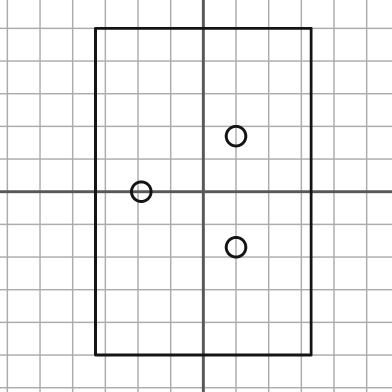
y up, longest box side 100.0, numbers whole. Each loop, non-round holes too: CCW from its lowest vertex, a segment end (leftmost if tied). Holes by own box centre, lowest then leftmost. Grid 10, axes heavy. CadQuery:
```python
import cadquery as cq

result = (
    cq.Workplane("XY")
    .moveTo(-33.0, -50.0)
    .lineTo(33.0, -50.0)
    .lineTo(33.0, 50.0)
    .lineTo(-33.0, 50.0)
    .close()
    .moveTo(10.0, -17.0)
    .circle(3.0)
    .moveTo(-19.0, 0.0)
    .circle(3.0)
    .moveTo(10.0, 17.0)
    .circle(3.0)
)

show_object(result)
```